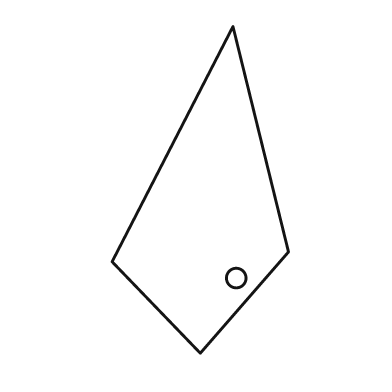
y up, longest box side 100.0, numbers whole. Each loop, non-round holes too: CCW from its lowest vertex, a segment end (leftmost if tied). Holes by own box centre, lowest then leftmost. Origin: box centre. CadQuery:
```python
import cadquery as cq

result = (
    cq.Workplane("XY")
    .moveTo(0.0, -50.0)
    .lineTo(27.0, -19.0)
    .lineTo(10.0, 50.0)
    .lineTo(-27.0, -22.0)
    .close()
    .moveTo(11.0, -27.0)
    .circle(3.0)
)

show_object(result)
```